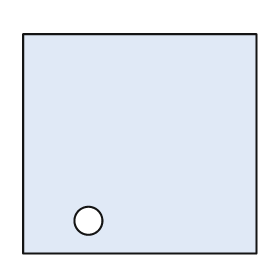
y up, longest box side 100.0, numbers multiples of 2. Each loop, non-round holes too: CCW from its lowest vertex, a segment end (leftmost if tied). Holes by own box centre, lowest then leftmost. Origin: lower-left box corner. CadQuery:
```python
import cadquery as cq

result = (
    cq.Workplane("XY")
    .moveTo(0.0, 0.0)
    .lineTo(100.0, 0.0)
    .lineTo(100.0, 94.0)
    .lineTo(0.0, 94.0)
    .close()
    .moveTo(28.0, 14.0)
    .circle(6.0)
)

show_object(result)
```